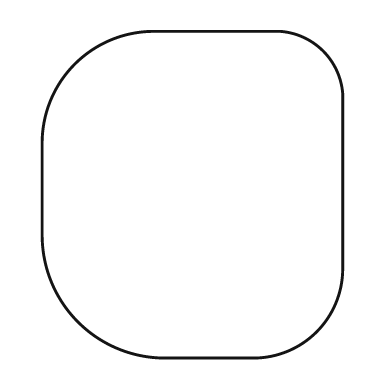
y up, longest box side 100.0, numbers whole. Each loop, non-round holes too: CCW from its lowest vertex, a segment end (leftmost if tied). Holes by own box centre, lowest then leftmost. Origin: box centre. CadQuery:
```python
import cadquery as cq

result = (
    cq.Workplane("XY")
    .moveTo(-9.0, -50.0)
    .lineTo(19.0, -50.0)
    .threePointArc((38.0, -42.0), (46.0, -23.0))
    .lineTo(46.0, 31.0)
    .threePointArc((40.0, 44.0), (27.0, 50.0))
    .lineTo(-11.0, 50.0)
    .threePointArc((-36.0, 40.0), (-46.0, 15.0))
    .lineTo(-46.0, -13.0)
    .threePointArc((-35.0, -39.0), (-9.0, -50.0))
    .close()
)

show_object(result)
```